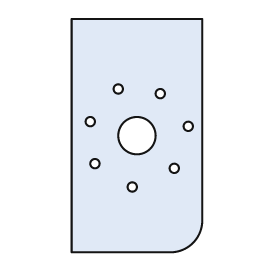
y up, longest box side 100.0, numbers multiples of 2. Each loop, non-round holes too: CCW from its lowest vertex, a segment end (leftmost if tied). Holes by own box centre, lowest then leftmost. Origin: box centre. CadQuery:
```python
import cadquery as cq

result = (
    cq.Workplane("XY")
    .moveTo(-28.0, -50.0)
    .lineTo(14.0, -50.0)
    .threePointArc((24.0, -46.0), (28.0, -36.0))
    .lineTo(28.0, 50.0)
    .lineTo(-28.0, 50.0)
    .close()
    .moveTo(-2.0, -22.0)
    .circle(2.0)
    .moveTo(16.0, -14.0)
    .circle(2.0)
    .moveTo(-18.0, -12.0)
    .circle(2.0)
    .moveTo(0.0, 0.0)
    .circle(8.0)
    .moveTo(22.0, 4.0)
    .circle(2.0)
    .moveTo(-20.0, 6.0)
    .circle(2.0)
    .moveTo(10.0, 18.0)
    .circle(2.0)
    .moveTo(-8.0, 20.0)
    .circle(2.0)
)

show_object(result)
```